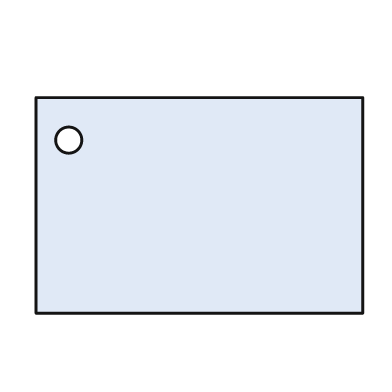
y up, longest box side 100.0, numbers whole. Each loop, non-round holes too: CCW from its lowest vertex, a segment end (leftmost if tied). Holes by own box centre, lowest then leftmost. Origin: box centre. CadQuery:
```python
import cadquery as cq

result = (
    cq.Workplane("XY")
    .moveTo(-50.0, -33.0)
    .lineTo(50.0, -33.0)
    .lineTo(50.0, 33.0)
    .lineTo(-50.0, 33.0)
    .close()
    .moveTo(-40.0, 20.0)
    .circle(4.0)
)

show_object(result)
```